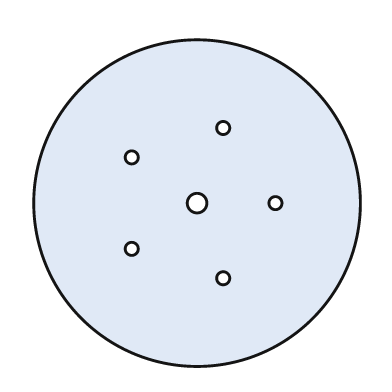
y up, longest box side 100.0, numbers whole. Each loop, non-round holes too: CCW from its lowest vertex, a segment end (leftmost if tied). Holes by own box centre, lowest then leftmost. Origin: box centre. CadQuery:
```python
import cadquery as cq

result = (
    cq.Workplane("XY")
    .moveTo(0.0, 0.0)
    .circle(50.0)
    .moveTo(8.0, -23.0)
    .circle(2.0)
    .moveTo(-20.0, -14.0)
    .circle(2.0)
    .moveTo(0.0, 0.0)
    .circle(3.0)
    .moveTo(24.0, 0.0)
    .circle(2.0)
    .moveTo(-20.0, 14.0)
    .circle(2.0)
    .moveTo(8.0, 23.0)
    .circle(2.0)
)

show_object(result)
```